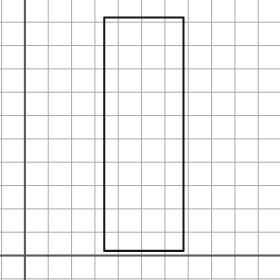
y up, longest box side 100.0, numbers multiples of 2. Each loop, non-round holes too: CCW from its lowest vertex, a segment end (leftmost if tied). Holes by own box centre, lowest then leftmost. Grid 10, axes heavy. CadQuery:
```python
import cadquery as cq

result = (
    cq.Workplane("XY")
    .moveTo(34.0, 2.0)
    .lineTo(68.0, 2.0)
    .lineTo(68.0, 102.0)
    .lineTo(34.0, 102.0)
    .close()
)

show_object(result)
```